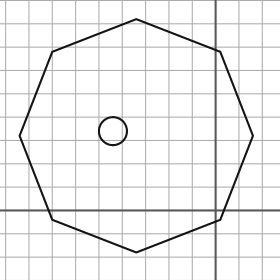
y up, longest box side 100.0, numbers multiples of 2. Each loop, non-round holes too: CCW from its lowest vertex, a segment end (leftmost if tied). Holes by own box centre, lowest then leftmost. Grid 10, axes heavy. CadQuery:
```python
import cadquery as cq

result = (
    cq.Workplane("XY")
    .moveTo(-34.0, -18.0)
    .lineTo(2.0, -4.0)
    .lineTo(16.0, 32.0)
    .lineTo(2.0, 68.0)
    .lineTo(-34.0, 82.0)
    .lineTo(-70.0, 68.0)
    .lineTo(-84.0, 32.0)
    .lineTo(-70.0, -4.0)
    .close()
    .moveTo(-44.0, 34.0)
    .circle(6.0)
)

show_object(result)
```